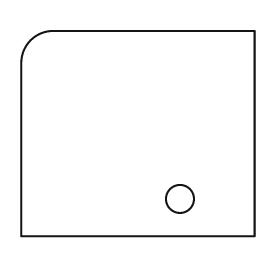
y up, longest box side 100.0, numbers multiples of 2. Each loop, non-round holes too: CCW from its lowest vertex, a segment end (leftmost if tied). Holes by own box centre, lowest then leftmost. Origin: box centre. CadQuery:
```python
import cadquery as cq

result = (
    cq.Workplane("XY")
    .moveTo(-50.0, -44.0)
    .lineTo(50.0, -44.0)
    .lineTo(50.0, 44.0)
    .lineTo(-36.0, 44.0)
    .threePointArc((-46.0, 40.0), (-50.0, 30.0))
    .close()
    .moveTo(18.0, -28.0)
    .circle(6.0)
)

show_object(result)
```